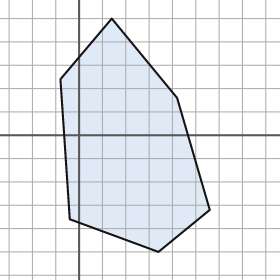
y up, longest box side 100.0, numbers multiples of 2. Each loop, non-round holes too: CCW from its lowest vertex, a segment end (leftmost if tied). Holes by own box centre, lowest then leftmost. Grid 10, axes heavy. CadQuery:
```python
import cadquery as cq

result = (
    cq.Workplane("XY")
    .moveTo(34.0, -50.0)
    .lineTo(56.0, -32.0)
    .lineTo(42.0, 16.0)
    .lineTo(14.0, 50.0)
    .lineTo(-8.0, 24.0)
    .lineTo(-4.0, -36.0)
    .close()
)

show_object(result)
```